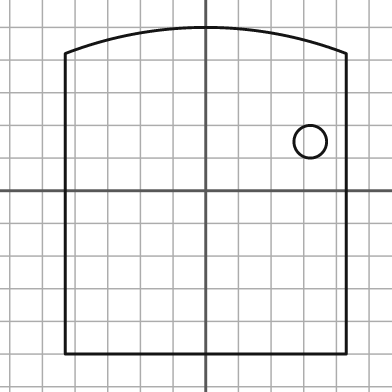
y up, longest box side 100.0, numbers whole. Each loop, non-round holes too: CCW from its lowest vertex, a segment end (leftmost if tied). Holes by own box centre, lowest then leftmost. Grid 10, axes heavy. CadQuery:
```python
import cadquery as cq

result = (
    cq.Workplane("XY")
    .moveTo(-43.0, -50.0)
    .lineTo(43.0, -50.0)
    .lineTo(43.0, 42.0)
    .threePointArc((0.0, 50.0), (-43.0, 42.0))
    .close()
    .moveTo(32.0, 15.0)
    .circle(5.0)
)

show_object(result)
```